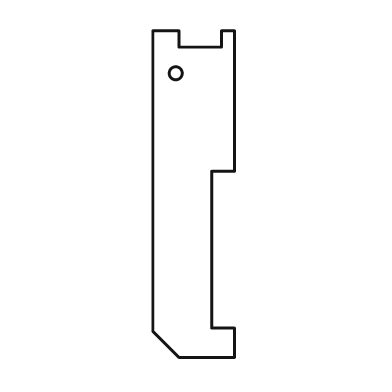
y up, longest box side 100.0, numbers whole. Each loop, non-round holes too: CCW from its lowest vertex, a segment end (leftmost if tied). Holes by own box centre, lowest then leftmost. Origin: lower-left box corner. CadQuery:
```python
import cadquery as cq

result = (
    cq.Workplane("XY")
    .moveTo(8.0, 0.0)
    .lineTo(25.0, 0.0)
    .lineTo(25.0, 9.0)
    .lineTo(18.0, 9.0)
    .lineTo(18.0, 57.0)
    .lineTo(25.0, 57.0)
    .lineTo(25.0, 100.0)
    .lineTo(21.0, 100.0)
    .lineTo(21.0, 95.0)
    .lineTo(8.0, 95.0)
    .lineTo(8.0, 100.0)
    .lineTo(0.0, 100.0)
    .lineTo(0.0, 8.0)
    .close()
    .moveTo(7.0, 87.0)
    .circle(2.0)
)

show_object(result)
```